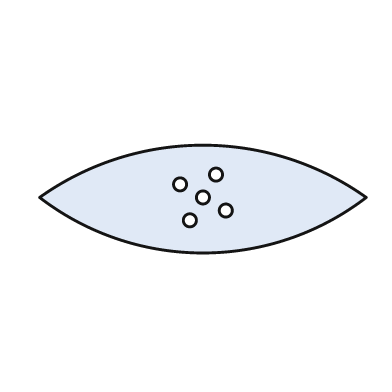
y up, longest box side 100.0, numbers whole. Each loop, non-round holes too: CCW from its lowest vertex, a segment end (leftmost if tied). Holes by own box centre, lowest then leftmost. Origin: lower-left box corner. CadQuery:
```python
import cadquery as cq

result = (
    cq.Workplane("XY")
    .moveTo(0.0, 17.0)
    .threePointArc((50.0, 0.0), (100.0, 17.0))
    .threePointArc((50.0, 33.0), (0.0, 17.0))
    .close()
    .moveTo(46.0, 10.0)
    .circle(2.0)
    .moveTo(57.0, 13.0)
    .circle(2.0)
    .moveTo(50.0, 17.0)
    .circle(2.0)
    .moveTo(43.0, 21.0)
    .circle(2.0)
    .moveTo(54.0, 24.0)
    .circle(2.0)
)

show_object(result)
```